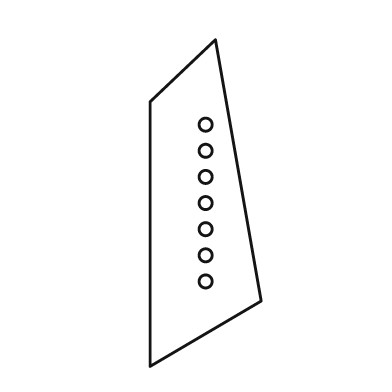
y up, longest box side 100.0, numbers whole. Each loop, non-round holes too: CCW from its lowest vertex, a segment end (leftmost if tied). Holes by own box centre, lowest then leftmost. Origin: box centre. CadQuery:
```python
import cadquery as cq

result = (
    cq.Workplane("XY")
    .moveTo(-17.0, -50.0)
    .lineTo(17.0, -30.0)
    .lineTo(3.0, 50.0)
    .lineTo(-17.0, 31.0)
    .close()
    .moveTo(0.0, -24.0)
    .circle(2.0)
    .moveTo(0.0, -16.0)
    .circle(2.0)
    .moveTo(0.0, -8.0)
    .circle(2.0)
    .moveTo(0.0, 0.0)
    .circle(2.0)
    .moveTo(0.0, 8.0)
    .circle(2.0)
    .moveTo(0.0, 16.0)
    .circle(2.0)
    .moveTo(0.0, 24.0)
    .circle(2.0)
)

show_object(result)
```